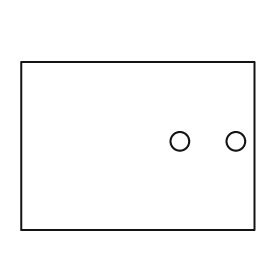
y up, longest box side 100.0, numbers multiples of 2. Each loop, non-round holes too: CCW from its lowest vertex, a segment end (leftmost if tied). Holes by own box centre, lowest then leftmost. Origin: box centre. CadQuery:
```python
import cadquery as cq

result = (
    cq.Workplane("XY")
    .moveTo(-50.0, -36.0)
    .lineTo(50.0, -36.0)
    .lineTo(50.0, 36.0)
    .lineTo(-50.0, 36.0)
    .close()
    .moveTo(18.0, 2.0)
    .circle(4.0)
    .moveTo(42.0, 2.0)
    .circle(4.0)
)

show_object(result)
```